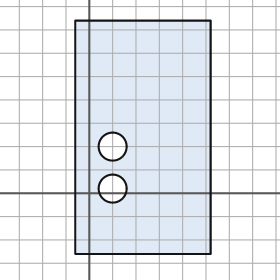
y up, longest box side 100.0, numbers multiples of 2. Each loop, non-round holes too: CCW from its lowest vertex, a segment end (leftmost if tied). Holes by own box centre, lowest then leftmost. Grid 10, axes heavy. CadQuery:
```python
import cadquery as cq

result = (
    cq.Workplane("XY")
    .moveTo(-6.0, -26.0)
    .lineTo(52.0, -26.0)
    .lineTo(52.0, 74.0)
    .lineTo(-6.0, 74.0)
    .close()
    .moveTo(10.0, 2.0)
    .circle(6.0)
    .moveTo(10.0, 20.0)
    .circle(6.0)
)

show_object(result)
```